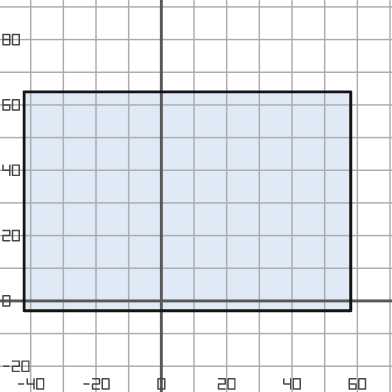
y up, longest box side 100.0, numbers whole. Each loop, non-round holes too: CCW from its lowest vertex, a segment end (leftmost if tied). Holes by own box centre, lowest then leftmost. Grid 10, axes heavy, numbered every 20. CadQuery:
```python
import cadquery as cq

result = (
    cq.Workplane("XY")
    .moveTo(-42.0, -3.0)
    .lineTo(58.0, -3.0)
    .lineTo(58.0, 64.0)
    .lineTo(-42.0, 64.0)
    .close()
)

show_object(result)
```